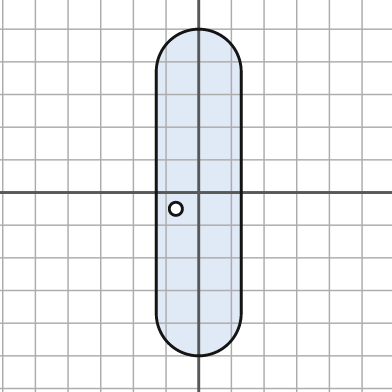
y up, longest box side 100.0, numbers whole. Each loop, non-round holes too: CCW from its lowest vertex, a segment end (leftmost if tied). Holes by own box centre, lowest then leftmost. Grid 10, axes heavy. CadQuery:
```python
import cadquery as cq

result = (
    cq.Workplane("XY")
    .moveTo(-13.0, -37.0)
    .threePointArc((0.0, -50.0), (13.0, -37.0))
    .lineTo(13.0, 37.0)
    .threePointArc((0.0, 50.0), (-13.0, 37.0))
    .close()
    .moveTo(-7.0, -5.0)
    .circle(2.0)
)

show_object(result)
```